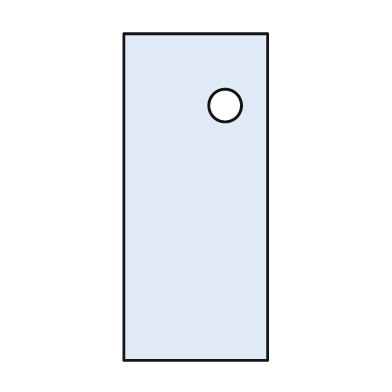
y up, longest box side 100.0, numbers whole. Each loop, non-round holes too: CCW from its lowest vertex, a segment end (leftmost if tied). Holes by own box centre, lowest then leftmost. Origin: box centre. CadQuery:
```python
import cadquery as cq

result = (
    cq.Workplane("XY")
    .moveTo(-22.0, -50.0)
    .lineTo(22.0, -50.0)
    .lineTo(22.0, 50.0)
    .lineTo(-22.0, 50.0)
    .close()
    .moveTo(9.0, 28.0)
    .circle(5.0)
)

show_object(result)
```